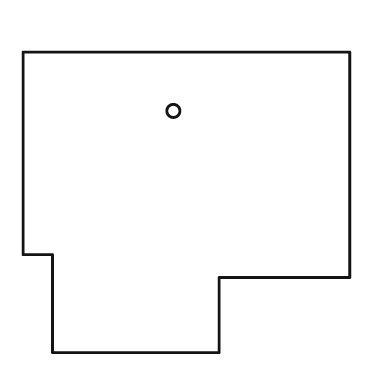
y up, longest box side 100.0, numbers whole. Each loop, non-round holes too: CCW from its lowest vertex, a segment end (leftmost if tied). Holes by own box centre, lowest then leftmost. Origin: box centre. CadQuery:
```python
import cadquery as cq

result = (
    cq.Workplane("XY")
    .moveTo(-41.0, -46.0)
    .lineTo(10.0, -46.0)
    .lineTo(10.0, -23.0)
    .lineTo(50.0, -23.0)
    .lineTo(50.0, 46.0)
    .lineTo(-50.0, 46.0)
    .lineTo(-50.0, -16.0)
    .lineTo(-41.0, -16.0)
    .close()
    .moveTo(-4.0, 28.0)
    .circle(2.0)
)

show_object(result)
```